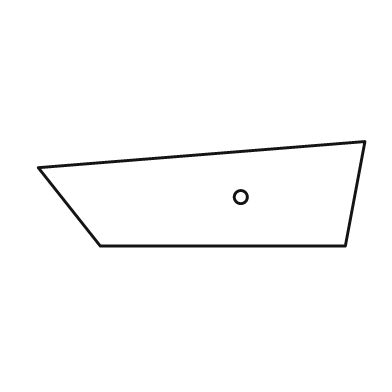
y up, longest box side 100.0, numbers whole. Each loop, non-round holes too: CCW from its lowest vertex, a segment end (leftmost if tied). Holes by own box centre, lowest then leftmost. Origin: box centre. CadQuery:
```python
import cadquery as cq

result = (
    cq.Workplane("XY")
    .moveTo(-31.0, -16.0)
    .lineTo(44.0, -16.0)
    .lineTo(50.0, 16.0)
    .lineTo(-50.0, 8.0)
    .close()
    .moveTo(12.0, -1.0)
    .circle(2.0)
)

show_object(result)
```